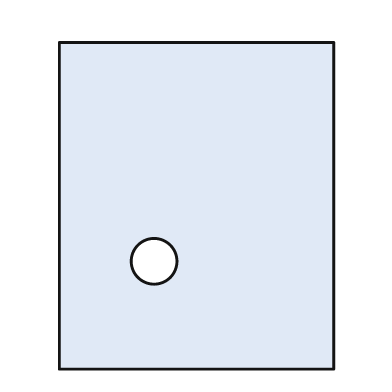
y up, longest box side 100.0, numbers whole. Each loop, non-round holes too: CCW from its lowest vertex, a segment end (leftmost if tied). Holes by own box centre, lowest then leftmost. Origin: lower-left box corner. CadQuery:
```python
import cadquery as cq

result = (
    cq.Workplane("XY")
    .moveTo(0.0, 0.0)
    .lineTo(84.0, 0.0)
    .lineTo(84.0, 100.0)
    .lineTo(0.0, 100.0)
    .close()
    .moveTo(29.0, 33.0)
    .circle(7.0)
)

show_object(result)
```